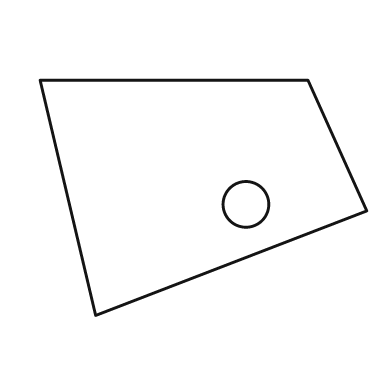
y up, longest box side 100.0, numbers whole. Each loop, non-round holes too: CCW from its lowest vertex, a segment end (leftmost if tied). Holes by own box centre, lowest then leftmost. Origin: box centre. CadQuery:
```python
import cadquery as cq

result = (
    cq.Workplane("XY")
    .moveTo(-33.0, -36.0)
    .lineTo(50.0, -4.0)
    .lineTo(32.0, 36.0)
    .lineTo(-50.0, 36.0)
    .close()
    .moveTo(13.0, -2.0)
    .circle(7.0)
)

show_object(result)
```